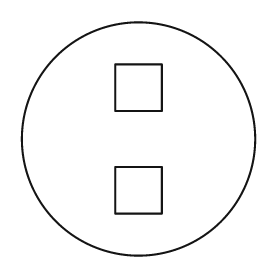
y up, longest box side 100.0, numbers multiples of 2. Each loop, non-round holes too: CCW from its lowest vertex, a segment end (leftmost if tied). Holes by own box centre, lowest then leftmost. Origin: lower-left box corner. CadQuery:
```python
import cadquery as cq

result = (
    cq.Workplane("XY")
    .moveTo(50.0, 50.0)
    .circle(50.0)
    .moveTo(40.0, 18.0)
    .lineTo(60.0, 18.0)
    .lineTo(60.0, 38.0)
    .lineTo(40.0, 38.0)
    .close()
    .moveTo(40.0, 62.0)
    .lineTo(60.0, 62.0)
    .lineTo(60.0, 82.0)
    .lineTo(40.0, 82.0)
    .close()
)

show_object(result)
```